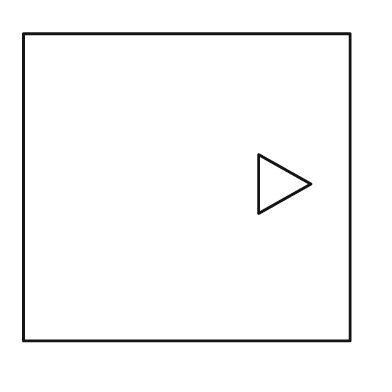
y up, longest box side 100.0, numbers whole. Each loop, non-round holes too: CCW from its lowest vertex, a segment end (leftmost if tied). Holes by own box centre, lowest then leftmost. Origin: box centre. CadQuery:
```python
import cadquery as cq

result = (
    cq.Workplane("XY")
    .moveTo(-50.0, -47.0)
    .lineTo(50.0, -47.0)
    .lineTo(50.0, 47.0)
    .lineTo(-50.0, 47.0)
    .close()
    .moveTo(22.0, -8.0)
    .lineTo(38.0, 1.0)
    .lineTo(22.0, 10.0)
    .close()
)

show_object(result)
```